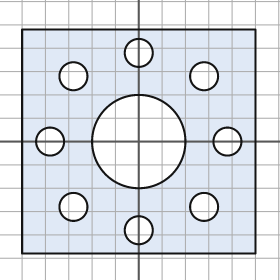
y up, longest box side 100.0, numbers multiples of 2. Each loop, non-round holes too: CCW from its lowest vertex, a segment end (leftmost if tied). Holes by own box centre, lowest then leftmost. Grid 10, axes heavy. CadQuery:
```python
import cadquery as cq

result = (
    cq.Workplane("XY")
    .moveTo(-50.0, -48.0)
    .lineTo(50.0, -48.0)
    .lineTo(50.0, 48.0)
    .lineTo(-50.0, 48.0)
    .close()
    .moveTo(0.0, -38.0)
    .circle(6.0)
    .moveTo(-28.0, -28.0)
    .circle(6.0)
    .moveTo(28.0, -28.0)
    .circle(6.0)
    .moveTo(-38.0, 0.0)
    .circle(6.0)
    .moveTo(0.0, 0.0)
    .circle(20.0)
    .moveTo(38.0, 0.0)
    .circle(6.0)
    .moveTo(-28.0, 28.0)
    .circle(6.0)
    .moveTo(28.0, 28.0)
    .circle(6.0)
    .moveTo(0.0, 38.0)
    .circle(6.0)
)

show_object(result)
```